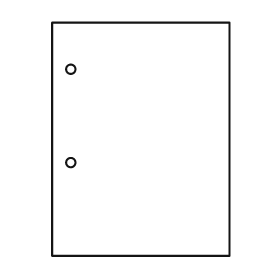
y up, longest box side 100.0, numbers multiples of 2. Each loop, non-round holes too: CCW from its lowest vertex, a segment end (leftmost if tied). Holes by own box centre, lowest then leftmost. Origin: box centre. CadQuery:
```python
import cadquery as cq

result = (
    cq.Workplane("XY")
    .moveTo(-38.0, -50.0)
    .lineTo(38.0, -50.0)
    .lineTo(38.0, 50.0)
    .lineTo(-38.0, 50.0)
    .close()
    .moveTo(-30.0, -10.0)
    .circle(2.0)
    .moveTo(-30.0, 30.0)
    .circle(2.0)
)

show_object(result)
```